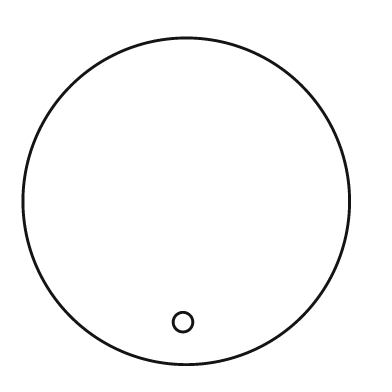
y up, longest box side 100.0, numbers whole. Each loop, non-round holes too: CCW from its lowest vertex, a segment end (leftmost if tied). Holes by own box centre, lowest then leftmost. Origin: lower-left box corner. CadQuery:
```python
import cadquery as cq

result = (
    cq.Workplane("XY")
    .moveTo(50.0, 50.0)
    .circle(50.0)
    .moveTo(49.0, 13.0)
    .circle(3.0)
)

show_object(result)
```